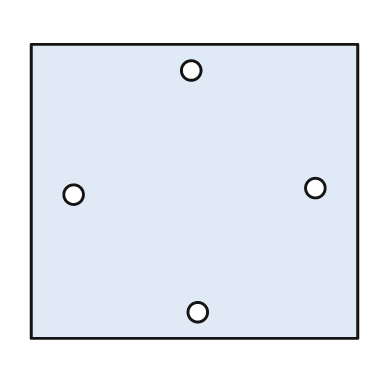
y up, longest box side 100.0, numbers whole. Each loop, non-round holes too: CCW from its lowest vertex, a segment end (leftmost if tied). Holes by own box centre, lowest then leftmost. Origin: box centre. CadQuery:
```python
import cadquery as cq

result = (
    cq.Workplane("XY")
    .moveTo(-50.0, -45.0)
    .lineTo(50.0, -45.0)
    .lineTo(50.0, 45.0)
    .lineTo(-50.0, 45.0)
    .close()
    .moveTo(1.0, -37.0)
    .circle(3.0)
    .moveTo(-37.0, -1.0)
    .circle(3.0)
    .moveTo(37.0, 1.0)
    .circle(3.0)
    .moveTo(-1.0, 37.0)
    .circle(3.0)
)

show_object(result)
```